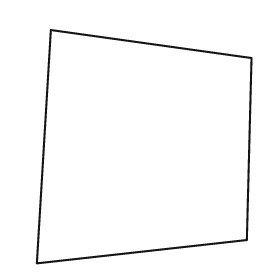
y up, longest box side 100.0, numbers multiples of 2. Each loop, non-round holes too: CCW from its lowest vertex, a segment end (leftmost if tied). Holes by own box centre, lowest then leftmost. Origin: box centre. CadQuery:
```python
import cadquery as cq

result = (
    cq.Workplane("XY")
    .moveTo(-46.0, -50.0)
    .lineTo(44.0, -40.0)
    .lineTo(46.0, 38.0)
    .lineTo(-40.0, 50.0)
    .close()
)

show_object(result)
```